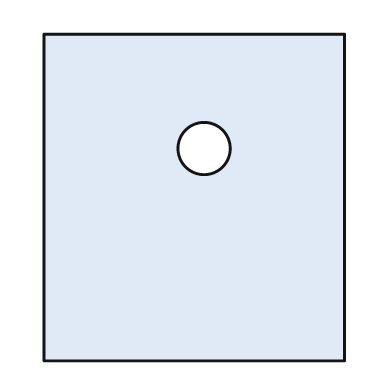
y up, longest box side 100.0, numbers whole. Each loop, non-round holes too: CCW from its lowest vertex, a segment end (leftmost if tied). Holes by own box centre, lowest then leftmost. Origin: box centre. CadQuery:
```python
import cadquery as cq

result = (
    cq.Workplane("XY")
    .moveTo(-46.0, -50.0)
    .lineTo(46.0, -50.0)
    .lineTo(46.0, 50.0)
    .lineTo(-46.0, 50.0)
    .close()
    .moveTo(3.0, 15.0)
    .circle(8.0)
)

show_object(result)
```